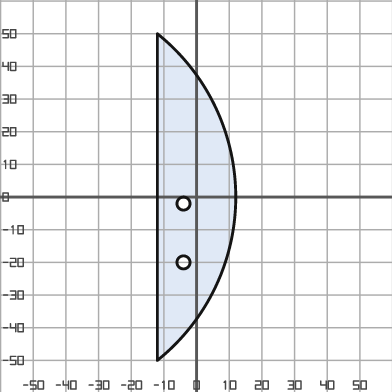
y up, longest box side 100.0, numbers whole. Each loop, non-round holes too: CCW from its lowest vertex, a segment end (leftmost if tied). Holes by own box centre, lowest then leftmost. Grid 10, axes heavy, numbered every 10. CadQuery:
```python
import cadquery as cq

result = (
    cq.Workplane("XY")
    .moveTo(-12.0, -50.0)
    .threePointArc((12.0, 0.0), (-12.0, 50.0))
    .close()
    .moveTo(-4.0, -20.0)
    .circle(2.0)
    .moveTo(-4.0, -2.0)
    .circle(2.0)
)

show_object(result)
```